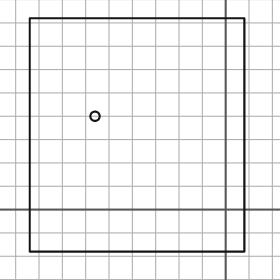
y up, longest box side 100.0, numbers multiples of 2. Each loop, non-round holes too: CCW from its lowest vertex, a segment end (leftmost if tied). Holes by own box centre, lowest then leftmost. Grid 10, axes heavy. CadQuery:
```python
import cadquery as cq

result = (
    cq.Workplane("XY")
    .moveTo(-84.0, -18.0)
    .lineTo(8.0, -18.0)
    .lineTo(8.0, 82.0)
    .lineTo(-84.0, 82.0)
    .close()
    .moveTo(-56.0, 40.0)
    .circle(2.0)
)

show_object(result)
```